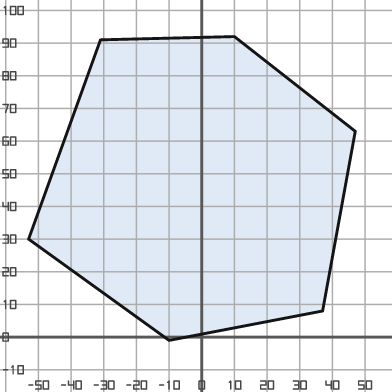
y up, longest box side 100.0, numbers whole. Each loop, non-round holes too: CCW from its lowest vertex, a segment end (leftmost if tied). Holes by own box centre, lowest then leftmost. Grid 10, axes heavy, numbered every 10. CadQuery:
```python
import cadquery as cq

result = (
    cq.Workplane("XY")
    .moveTo(-10.0, -1.0)
    .lineTo(37.0, 8.0)
    .lineTo(47.0, 63.0)
    .lineTo(10.0, 92.0)
    .lineTo(-31.0, 91.0)
    .lineTo(-53.0, 30.0)
    .close()
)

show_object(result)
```